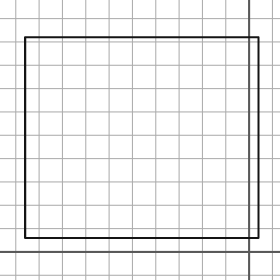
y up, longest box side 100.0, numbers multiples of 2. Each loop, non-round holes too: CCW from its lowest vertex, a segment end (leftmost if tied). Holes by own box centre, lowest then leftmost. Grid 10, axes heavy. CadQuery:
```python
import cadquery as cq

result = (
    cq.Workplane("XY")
    .moveTo(-96.0, 6.0)
    .lineTo(4.0, 6.0)
    .lineTo(4.0, 92.0)
    .lineTo(-96.0, 92.0)
    .close()
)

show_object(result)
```